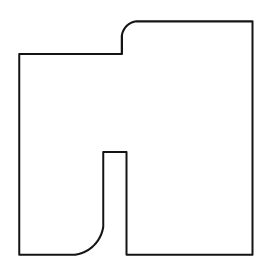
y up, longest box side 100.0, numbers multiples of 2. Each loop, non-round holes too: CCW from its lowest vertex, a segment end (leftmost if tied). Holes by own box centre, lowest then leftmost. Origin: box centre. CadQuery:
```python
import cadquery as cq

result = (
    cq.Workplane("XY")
    .moveTo(-50.0, -50.0)
    .lineTo(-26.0, -50.0)
    .threePointArc((-18.0, -46.0), (-14.0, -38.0))
    .lineTo(-14.0, -6.0)
    .lineTo(-4.0, -6.0)
    .lineTo(-4.0, -50.0)
    .lineTo(50.0, -50.0)
    .lineTo(50.0, 50.0)
    .lineTo(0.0, 50.0)
    .threePointArc((-4.0, 48.0), (-6.0, 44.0))
    .lineTo(-6.0, 36.0)
    .lineTo(-50.0, 36.0)
    .close()
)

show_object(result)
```